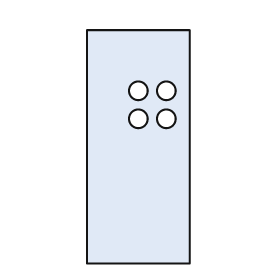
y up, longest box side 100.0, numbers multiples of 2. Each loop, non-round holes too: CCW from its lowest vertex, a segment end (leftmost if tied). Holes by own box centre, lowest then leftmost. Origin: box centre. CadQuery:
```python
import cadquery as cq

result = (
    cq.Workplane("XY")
    .moveTo(-22.0, -50.0)
    .lineTo(22.0, -50.0)
    .lineTo(22.0, 50.0)
    .lineTo(-22.0, 50.0)
    .close()
    .moveTo(0.0, 12.0)
    .circle(4.0)
    .moveTo(12.0, 12.0)
    .circle(4.0)
    .moveTo(0.0, 24.0)
    .circle(4.0)
    .moveTo(12.0, 24.0)
    .circle(4.0)
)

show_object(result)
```